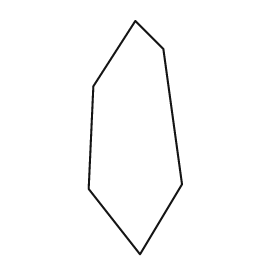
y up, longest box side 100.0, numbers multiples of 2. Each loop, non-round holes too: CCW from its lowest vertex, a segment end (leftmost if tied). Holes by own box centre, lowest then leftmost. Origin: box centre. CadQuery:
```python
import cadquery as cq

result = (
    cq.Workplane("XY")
    .moveTo(2.0, -50.0)
    .lineTo(20.0, -20.0)
    .lineTo(12.0, 38.0)
    .lineTo(0.0, 50.0)
    .lineTo(-18.0, 22.0)
    .lineTo(-20.0, -22.0)
    .close()
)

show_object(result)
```